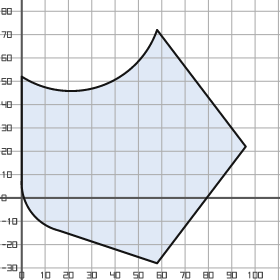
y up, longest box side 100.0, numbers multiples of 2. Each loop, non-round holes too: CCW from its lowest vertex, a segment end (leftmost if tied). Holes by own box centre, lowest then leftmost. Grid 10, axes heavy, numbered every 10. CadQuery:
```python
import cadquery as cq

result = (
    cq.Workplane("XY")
    .moveTo(58.0, -28.0)
    .lineTo(96.0, 22.0)
    .lineTo(58.0, 72.0)
    .threePointArc((34.0, 48.0), (0.0, 52.0))
    .lineTo(0.0, 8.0)
    .threePointArc((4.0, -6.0), (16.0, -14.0))
    .close()
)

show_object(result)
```